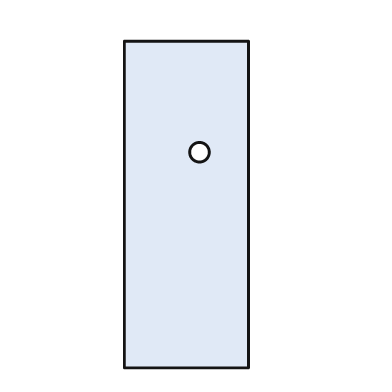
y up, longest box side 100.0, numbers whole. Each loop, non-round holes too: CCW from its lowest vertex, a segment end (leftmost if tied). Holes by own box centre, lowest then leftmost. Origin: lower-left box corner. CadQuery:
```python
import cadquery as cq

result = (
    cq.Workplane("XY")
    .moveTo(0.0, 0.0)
    .lineTo(38.0, 0.0)
    .lineTo(38.0, 100.0)
    .lineTo(0.0, 100.0)
    .close()
    .moveTo(23.0, 66.0)
    .circle(3.0)
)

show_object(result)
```